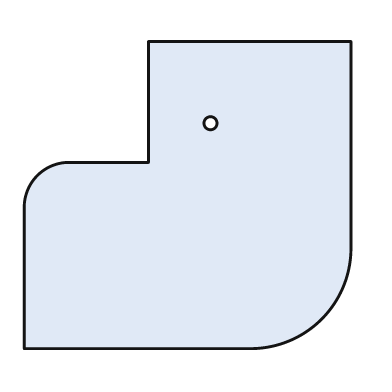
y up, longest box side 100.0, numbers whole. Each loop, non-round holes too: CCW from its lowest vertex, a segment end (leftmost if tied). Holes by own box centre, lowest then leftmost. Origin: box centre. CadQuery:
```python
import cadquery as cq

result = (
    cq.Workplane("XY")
    .moveTo(-50.0, -47.0)
    .lineTo(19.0, -47.0)
    .threePointArc((41.0, -38.0), (50.0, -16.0))
    .lineTo(50.0, 47.0)
    .lineTo(-12.0, 47.0)
    .lineTo(-12.0, 10.0)
    .lineTo(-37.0, 10.0)
    .threePointArc((-46.0, 6.0), (-50.0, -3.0))
    .close()
    .moveTo(7.0, 22.0)
    .circle(2.0)
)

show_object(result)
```